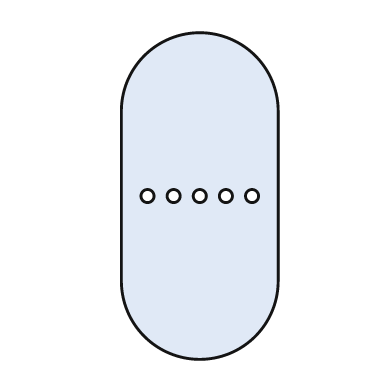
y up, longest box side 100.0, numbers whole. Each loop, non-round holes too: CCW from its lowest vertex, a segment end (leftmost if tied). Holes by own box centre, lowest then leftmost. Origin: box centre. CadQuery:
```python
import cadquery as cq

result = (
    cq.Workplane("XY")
    .moveTo(-24.0, -26.0)
    .threePointArc((0.0, -50.0), (24.0, -26.0))
    .lineTo(24.0, 26.0)
    .threePointArc((0.0, 50.0), (-24.0, 26.0))
    .close()
    .moveTo(-16.0, 0.0)
    .circle(2.0)
    .moveTo(-8.0, 0.0)
    .circle(2.0)
    .moveTo(0.0, 0.0)
    .circle(2.0)
    .moveTo(8.0, 0.0)
    .circle(2.0)
    .moveTo(16.0, 0.0)
    .circle(2.0)
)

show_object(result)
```